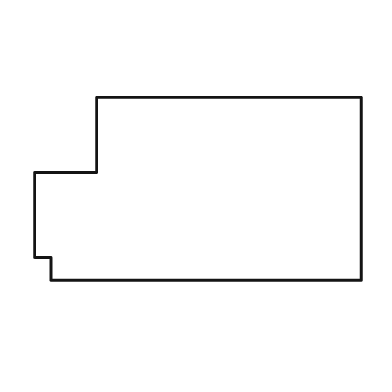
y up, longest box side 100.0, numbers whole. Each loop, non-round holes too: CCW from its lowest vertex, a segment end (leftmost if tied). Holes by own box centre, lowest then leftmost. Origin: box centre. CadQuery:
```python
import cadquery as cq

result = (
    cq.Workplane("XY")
    .moveTo(-45.0, -28.0)
    .lineTo(50.0, -28.0)
    .lineTo(50.0, 28.0)
    .lineTo(-31.0, 28.0)
    .lineTo(-31.0, 5.0)
    .lineTo(-50.0, 5.0)
    .lineTo(-50.0, -21.0)
    .lineTo(-45.0, -21.0)
    .close()
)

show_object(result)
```